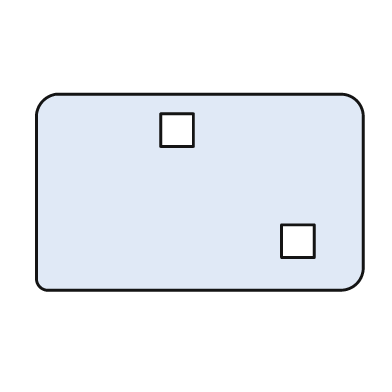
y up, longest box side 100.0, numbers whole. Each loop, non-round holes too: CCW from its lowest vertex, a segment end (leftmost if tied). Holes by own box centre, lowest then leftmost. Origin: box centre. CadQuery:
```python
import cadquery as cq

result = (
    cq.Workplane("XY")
    .moveTo(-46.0, -30.0)
    .lineTo(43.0, -30.0)
    .threePointArc((48.0, -28.0), (50.0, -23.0))
    .lineTo(50.0, 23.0)
    .threePointArc((48.0, 28.0), (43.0, 30.0))
    .lineTo(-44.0, 30.0)
    .threePointArc((-48.0, 28.0), (-50.0, 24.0))
    .lineTo(-50.0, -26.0)
    .threePointArc((-49.0, -29.0), (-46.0, -30.0))
    .close()
    .moveTo(25.0, -20.0)
    .lineTo(35.0, -20.0)
    .lineTo(35.0, -10.0)
    .lineTo(25.0, -10.0)
    .close()
    .moveTo(-12.0, 14.0)
    .lineTo(-2.0, 14.0)
    .lineTo(-2.0, 24.0)
    .lineTo(-12.0, 24.0)
    .close()
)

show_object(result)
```